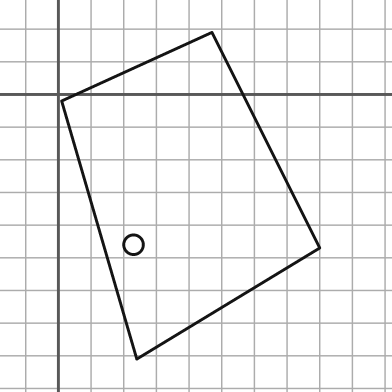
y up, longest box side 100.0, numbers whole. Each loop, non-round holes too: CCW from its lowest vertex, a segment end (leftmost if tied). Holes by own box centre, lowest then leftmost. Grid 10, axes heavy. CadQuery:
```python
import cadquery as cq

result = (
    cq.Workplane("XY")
    .moveTo(24.0, -81.0)
    .lineTo(80.0, -47.0)
    .lineTo(47.0, 19.0)
    .lineTo(1.0, -2.0)
    .close()
    .moveTo(23.0, -46.0)
    .circle(3.0)
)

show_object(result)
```